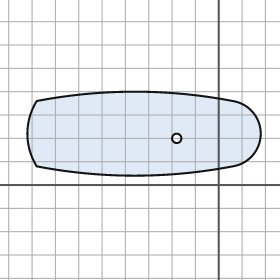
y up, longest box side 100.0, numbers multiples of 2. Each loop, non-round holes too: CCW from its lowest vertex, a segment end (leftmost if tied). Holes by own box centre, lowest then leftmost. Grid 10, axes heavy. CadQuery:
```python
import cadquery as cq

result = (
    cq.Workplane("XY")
    .moveTo(-78.0, 8.0)
    .threePointArc((-36.0, 4.0), (6.0, 8.0))
    .threePointArc((18.0, 22.0), (6.0, 36.0))
    .threePointArc((-36.0, 40.0), (-78.0, 36.0))
    .threePointArc((-82.0, 22.0), (-78.0, 8.0))
    .close()
    .moveTo(-18.0, 20.0)
    .circle(2.0)
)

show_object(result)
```